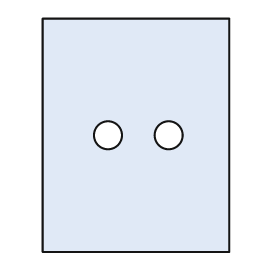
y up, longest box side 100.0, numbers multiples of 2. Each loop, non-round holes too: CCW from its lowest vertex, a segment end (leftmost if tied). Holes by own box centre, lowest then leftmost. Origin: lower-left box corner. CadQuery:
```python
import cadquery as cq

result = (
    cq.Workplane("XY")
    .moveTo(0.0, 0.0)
    .lineTo(80.0, 0.0)
    .lineTo(80.0, 100.0)
    .lineTo(0.0, 100.0)
    .close()
    .moveTo(28.0, 50.0)
    .circle(6.0)
    .moveTo(54.0, 50.0)
    .circle(6.0)
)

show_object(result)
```